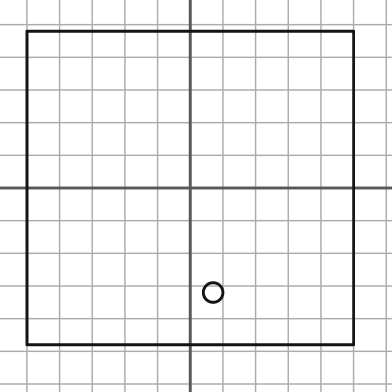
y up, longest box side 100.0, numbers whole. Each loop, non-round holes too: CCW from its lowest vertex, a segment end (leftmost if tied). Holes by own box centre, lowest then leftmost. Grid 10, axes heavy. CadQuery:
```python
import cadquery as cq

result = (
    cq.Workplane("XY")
    .moveTo(-50.0, -48.0)
    .lineTo(50.0, -48.0)
    .lineTo(50.0, 48.0)
    .lineTo(-50.0, 48.0)
    .close()
    .moveTo(7.0, -32.0)
    .circle(3.0)
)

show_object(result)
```